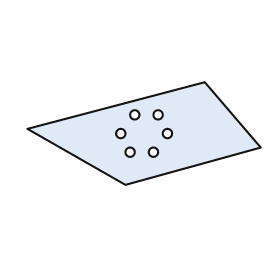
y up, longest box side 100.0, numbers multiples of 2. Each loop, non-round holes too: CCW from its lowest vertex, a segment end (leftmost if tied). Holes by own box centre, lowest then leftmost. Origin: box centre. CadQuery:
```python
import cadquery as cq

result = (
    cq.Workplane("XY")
    .moveTo(-8.0, -22.0)
    .lineTo(50.0, -6.0)
    .lineTo(26.0, 22.0)
    .lineTo(-50.0, 2.0)
    .close()
    .moveTo(-6.0, -8.0)
    .circle(2.0)
    .moveTo(4.0, -8.0)
    .circle(2.0)
    .moveTo(-10.0, 0.0)
    .circle(2.0)
    .moveTo(10.0, 0.0)
    .circle(2.0)
    .moveTo(-4.0, 8.0)
    .circle(2.0)
    .moveTo(6.0, 8.0)
    .circle(2.0)
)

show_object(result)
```